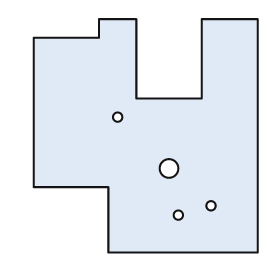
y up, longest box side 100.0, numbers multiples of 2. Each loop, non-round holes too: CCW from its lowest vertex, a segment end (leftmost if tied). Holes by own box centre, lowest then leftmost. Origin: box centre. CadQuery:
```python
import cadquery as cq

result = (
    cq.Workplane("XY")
    .moveTo(-16.0, -50.0)
    .lineTo(48.0, -50.0)
    .lineTo(48.0, 50.0)
    .lineTo(24.0, 50.0)
    .lineTo(24.0, 16.0)
    .lineTo(-4.0, 16.0)
    .lineTo(-4.0, 50.0)
    .lineTo(-20.0, 50.0)
    .lineTo(-20.0, 42.0)
    .lineTo(-48.0, 42.0)
    .lineTo(-48.0, -22.0)
    .lineTo(-16.0, -22.0)
    .close()
    .moveTo(14.0, -34.0)
    .circle(2.0)
    .moveTo(28.0, -30.0)
    .circle(2.0)
    .moveTo(10.0, -14.0)
    .circle(4.0)
    .moveTo(-12.0, 8.0)
    .circle(2.0)
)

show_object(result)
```